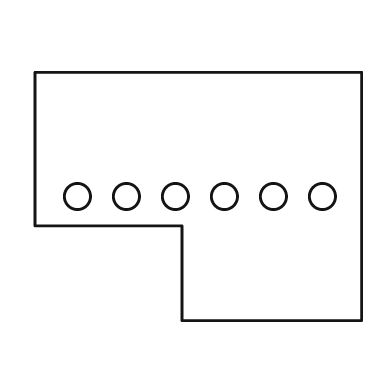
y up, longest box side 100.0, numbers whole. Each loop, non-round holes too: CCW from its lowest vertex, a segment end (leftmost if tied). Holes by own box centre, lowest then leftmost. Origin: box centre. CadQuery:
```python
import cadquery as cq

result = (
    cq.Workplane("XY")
    .moveTo(-5.0, -38.0)
    .lineTo(50.0, -38.0)
    .lineTo(50.0, 38.0)
    .lineTo(-50.0, 38.0)
    .lineTo(-50.0, -9.0)
    .lineTo(-5.0, -9.0)
    .close()
    .moveTo(-37.0, 0.0)
    .circle(4.0)
    .moveTo(-22.0, 0.0)
    .circle(4.0)
    .moveTo(-7.0, 0.0)
    .circle(4.0)
    .moveTo(8.0, 0.0)
    .circle(4.0)
    .moveTo(23.0, 0.0)
    .circle(4.0)
    .moveTo(38.0, 0.0)
    .circle(4.0)
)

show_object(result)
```